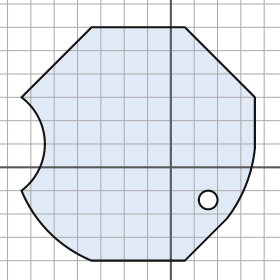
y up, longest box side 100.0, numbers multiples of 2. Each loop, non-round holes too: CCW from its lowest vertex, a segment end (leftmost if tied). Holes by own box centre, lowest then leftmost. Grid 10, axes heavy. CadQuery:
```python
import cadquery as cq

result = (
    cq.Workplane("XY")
    .moveTo(-34.0, -40.0)
    .lineTo(6.0, -40.0)
    .lineTo(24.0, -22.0)
    .threePointArc((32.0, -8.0), (36.0, 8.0))
    .lineTo(36.0, 30.0)
    .lineTo(6.0, 60.0)
    .lineTo(-34.0, 60.0)
    .lineTo(-64.0, 30.0)
    .threePointArc((-54.0, 10.0), (-64.0, -10.0))
    .threePointArc((-52.0, -28.0), (-34.0, -40.0))
    .close()
    .moveTo(16.0, -14.0)
    .circle(4.0)
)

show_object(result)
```